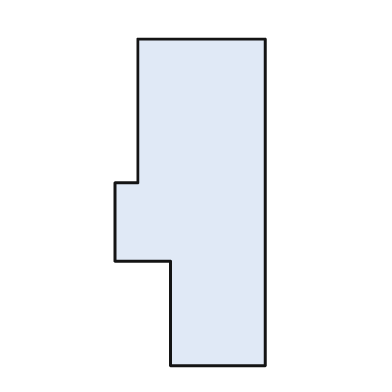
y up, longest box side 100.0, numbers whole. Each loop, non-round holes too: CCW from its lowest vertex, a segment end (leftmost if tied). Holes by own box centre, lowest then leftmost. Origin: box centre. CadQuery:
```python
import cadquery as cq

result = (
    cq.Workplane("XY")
    .moveTo(-6.0, -50.0)
    .lineTo(23.0, -50.0)
    .lineTo(23.0, 50.0)
    .lineTo(-16.0, 50.0)
    .lineTo(-16.0, 6.0)
    .lineTo(-23.0, 6.0)
    .lineTo(-23.0, -18.0)
    .lineTo(-6.0, -18.0)
    .close()
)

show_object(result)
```